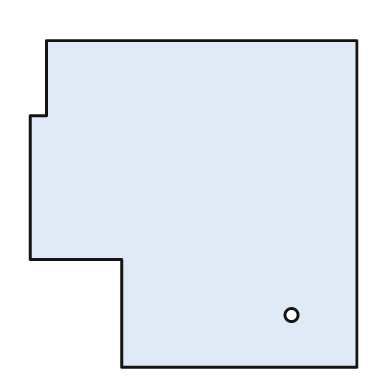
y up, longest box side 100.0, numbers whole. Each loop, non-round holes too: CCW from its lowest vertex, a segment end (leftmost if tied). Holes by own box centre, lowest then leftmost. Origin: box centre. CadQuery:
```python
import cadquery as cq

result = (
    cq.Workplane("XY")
    .moveTo(-22.0, -50.0)
    .lineTo(50.0, -50.0)
    .lineTo(50.0, 50.0)
    .lineTo(-45.0, 50.0)
    .lineTo(-45.0, 27.0)
    .lineTo(-50.0, 27.0)
    .lineTo(-50.0, -17.0)
    .lineTo(-22.0, -17.0)
    .close()
    .moveTo(30.0, -34.0)
    .circle(2.0)
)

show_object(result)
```